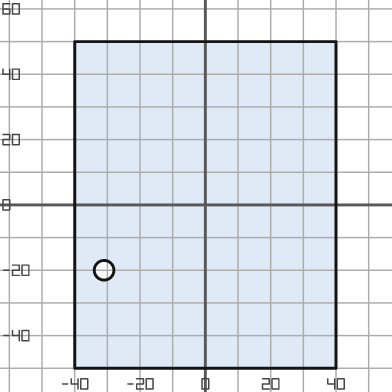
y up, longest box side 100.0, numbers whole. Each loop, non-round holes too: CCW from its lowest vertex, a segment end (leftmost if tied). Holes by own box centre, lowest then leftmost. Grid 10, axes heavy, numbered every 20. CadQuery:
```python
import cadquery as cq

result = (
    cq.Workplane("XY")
    .moveTo(-40.0, -50.0)
    .lineTo(40.0, -50.0)
    .lineTo(40.0, 50.0)
    .lineTo(-40.0, 50.0)
    .close()
    .moveTo(-31.0, -20.0)
    .circle(3.0)
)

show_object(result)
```